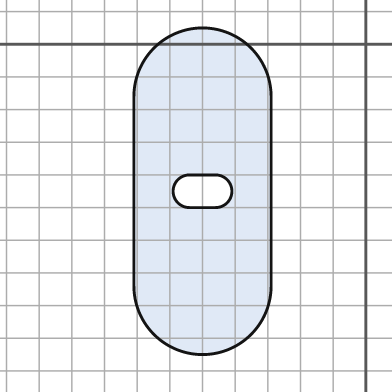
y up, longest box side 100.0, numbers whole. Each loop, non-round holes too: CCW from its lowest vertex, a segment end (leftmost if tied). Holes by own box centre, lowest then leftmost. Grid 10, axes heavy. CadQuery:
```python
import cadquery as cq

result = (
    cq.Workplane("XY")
    .moveTo(-71.0, -74.0)
    .threePointArc((-50.0, -95.0), (-29.0, -74.0))
    .lineTo(-29.0, -16.0)
    .threePointArc((-50.0, 5.0), (-71.0, -16.0))
    .close()
    .moveTo(-54.0, -50.0)
    .lineTo(-46.0, -50.0)
    .threePointArc((-41.0, -45.0), (-46.0, -40.0))
    .lineTo(-54.0, -40.0)
    .threePointArc((-59.0, -45.0), (-54.0, -50.0))
    .close()
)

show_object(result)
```